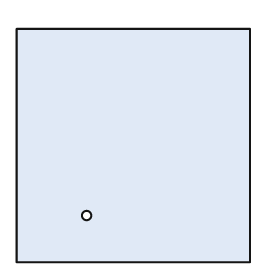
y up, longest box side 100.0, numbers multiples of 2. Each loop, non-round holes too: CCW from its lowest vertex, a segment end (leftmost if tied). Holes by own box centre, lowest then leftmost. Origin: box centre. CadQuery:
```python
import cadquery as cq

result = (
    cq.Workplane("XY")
    .moveTo(-50.0, -50.0)
    .lineTo(50.0, -50.0)
    .lineTo(50.0, 50.0)
    .lineTo(-50.0, 50.0)
    .close()
    .moveTo(-20.0, -30.0)
    .circle(2.0)
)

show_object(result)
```